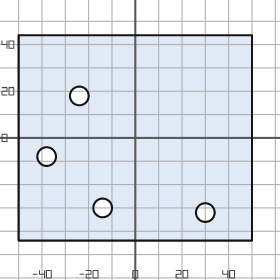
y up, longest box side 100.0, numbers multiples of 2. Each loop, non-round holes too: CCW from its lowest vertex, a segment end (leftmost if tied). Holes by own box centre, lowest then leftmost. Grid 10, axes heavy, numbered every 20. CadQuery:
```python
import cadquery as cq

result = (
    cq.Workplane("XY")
    .moveTo(-50.0, -44.0)
    .lineTo(50.0, -44.0)
    .lineTo(50.0, 44.0)
    .lineTo(-50.0, 44.0)
    .close()
    .moveTo(30.0, -32.0)
    .circle(4.0)
    .moveTo(-14.0, -30.0)
    .circle(4.0)
    .moveTo(-38.0, -8.0)
    .circle(4.0)
    .moveTo(-24.0, 18.0)
    .circle(4.0)
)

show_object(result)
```